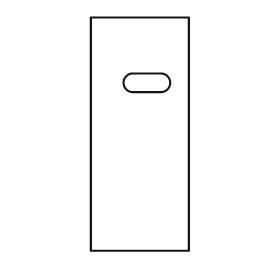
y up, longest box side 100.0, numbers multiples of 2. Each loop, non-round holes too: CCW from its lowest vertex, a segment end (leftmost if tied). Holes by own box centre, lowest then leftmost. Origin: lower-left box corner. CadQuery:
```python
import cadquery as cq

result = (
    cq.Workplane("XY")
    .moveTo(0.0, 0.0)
    .lineTo(42.0, 0.0)
    .lineTo(42.0, 100.0)
    .lineTo(0.0, 100.0)
    .close()
    .moveTo(18.0, 68.0)
    .lineTo(30.0, 68.0)
    .threePointArc((34.0, 72.0), (30.0, 76.0))
    .lineTo(18.0, 76.0)
    .threePointArc((14.0, 72.0), (18.0, 68.0))
    .close()
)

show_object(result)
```